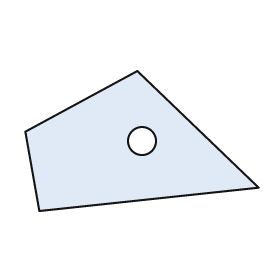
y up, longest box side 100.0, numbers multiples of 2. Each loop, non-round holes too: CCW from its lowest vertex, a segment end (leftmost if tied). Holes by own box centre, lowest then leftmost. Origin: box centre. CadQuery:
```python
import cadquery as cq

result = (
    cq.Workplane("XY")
    .moveTo(-44.0, -30.0)
    .lineTo(50.0, -20.0)
    .lineTo(-2.0, 30.0)
    .lineTo(-50.0, 4.0)
    .close()
    .moveTo(0.0, 0.0)
    .circle(6.0)
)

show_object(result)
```